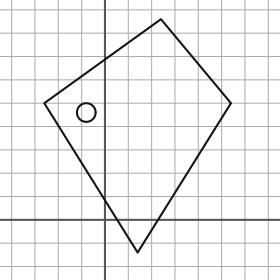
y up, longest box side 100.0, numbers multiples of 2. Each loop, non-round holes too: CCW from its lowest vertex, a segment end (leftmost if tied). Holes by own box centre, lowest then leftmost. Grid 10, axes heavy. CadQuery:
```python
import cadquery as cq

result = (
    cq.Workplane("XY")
    .moveTo(14.0, -14.0)
    .lineTo(54.0, 50.0)
    .lineTo(24.0, 86.0)
    .lineTo(-26.0, 50.0)
    .close()
    .moveTo(-8.0, 46.0)
    .circle(4.0)
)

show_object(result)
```